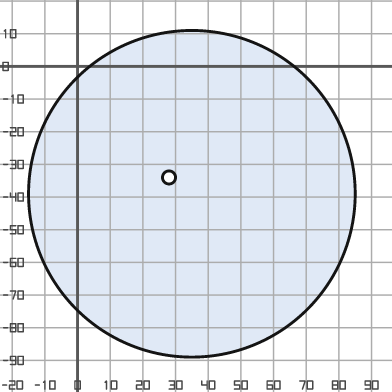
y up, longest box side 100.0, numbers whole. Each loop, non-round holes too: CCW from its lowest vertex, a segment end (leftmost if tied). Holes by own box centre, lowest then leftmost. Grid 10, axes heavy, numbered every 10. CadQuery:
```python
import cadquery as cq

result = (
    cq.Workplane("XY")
    .moveTo(35.0, -39.0)
    .circle(50.0)
    .moveTo(28.0, -34.0)
    .circle(2.0)
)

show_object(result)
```